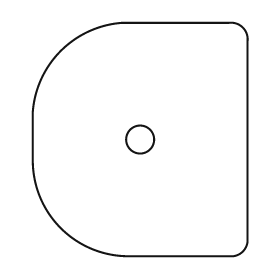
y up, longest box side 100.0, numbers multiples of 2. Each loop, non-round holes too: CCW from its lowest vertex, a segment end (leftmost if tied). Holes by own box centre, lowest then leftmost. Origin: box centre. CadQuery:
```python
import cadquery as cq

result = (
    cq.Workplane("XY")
    .moveTo(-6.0, -50.0)
    .lineTo(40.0, -50.0)
    .threePointArc((44.0, -48.0), (46.0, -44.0))
    .lineTo(46.0, 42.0)
    .threePointArc((44.0, 48.0), (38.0, 50.0))
    .lineTo(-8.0, 50.0)
    .threePointArc((-34.0, 38.0), (-46.0, 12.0))
    .lineTo(-46.0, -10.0)
    .threePointArc((-34.0, -38.0), (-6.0, -50.0))
    .close()
    .moveTo(0.0, 0.0)
    .circle(6.0)
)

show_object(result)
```